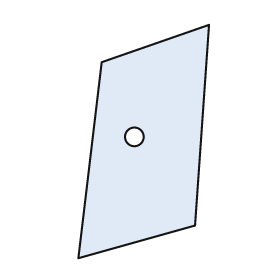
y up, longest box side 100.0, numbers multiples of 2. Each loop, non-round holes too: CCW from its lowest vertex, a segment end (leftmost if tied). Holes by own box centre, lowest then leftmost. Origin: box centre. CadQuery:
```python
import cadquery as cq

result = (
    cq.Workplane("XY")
    .moveTo(-28.0, -50.0)
    .lineTo(22.0, -36.0)
    .lineTo(28.0, 50.0)
    .lineTo(-18.0, 34.0)
    .close()
    .moveTo(-4.0, 2.0)
    .circle(4.0)
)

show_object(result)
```